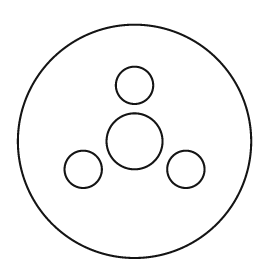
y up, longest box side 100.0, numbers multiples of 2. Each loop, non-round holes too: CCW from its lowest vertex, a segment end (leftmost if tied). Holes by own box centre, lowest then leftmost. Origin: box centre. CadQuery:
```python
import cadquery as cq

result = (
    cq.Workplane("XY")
    .moveTo(0.0, 0.0)
    .circle(50.0)
    .moveTo(-22.0, -12.0)
    .circle(8.0)
    .moveTo(22.0, -12.0)
    .circle(8.0)
    .moveTo(0.0, 0.0)
    .circle(12.0)
    .moveTo(0.0, 24.0)
    .circle(8.0)
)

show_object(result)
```